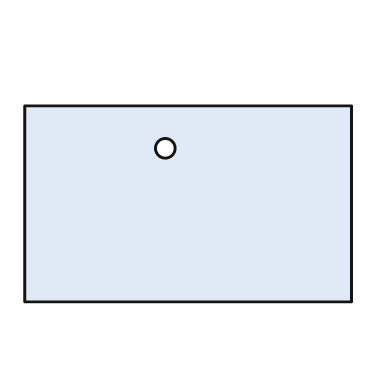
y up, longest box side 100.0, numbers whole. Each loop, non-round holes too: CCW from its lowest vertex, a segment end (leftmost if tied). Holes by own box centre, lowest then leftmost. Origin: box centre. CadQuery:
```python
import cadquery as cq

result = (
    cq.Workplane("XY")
    .moveTo(-50.0, -30.0)
    .lineTo(50.0, -30.0)
    .lineTo(50.0, 30.0)
    .lineTo(-50.0, 30.0)
    .close()
    .moveTo(-7.0, 17.0)
    .circle(3.0)
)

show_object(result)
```